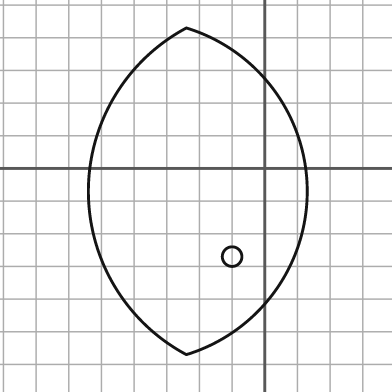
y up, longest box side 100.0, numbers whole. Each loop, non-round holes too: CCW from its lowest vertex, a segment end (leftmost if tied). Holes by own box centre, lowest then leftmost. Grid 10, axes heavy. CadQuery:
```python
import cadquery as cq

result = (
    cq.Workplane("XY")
    .moveTo(-24.0, -57.0)
    .threePointArc((13.0, -7.0), (-24.0, 43.0))
    .threePointArc((-54.0, -7.0), (-24.0, -57.0))
    .close()
    .moveTo(-10.0, -27.0)
    .circle(3.0)
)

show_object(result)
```